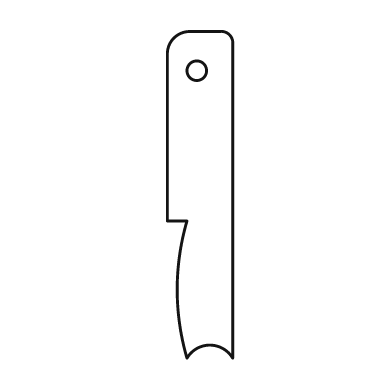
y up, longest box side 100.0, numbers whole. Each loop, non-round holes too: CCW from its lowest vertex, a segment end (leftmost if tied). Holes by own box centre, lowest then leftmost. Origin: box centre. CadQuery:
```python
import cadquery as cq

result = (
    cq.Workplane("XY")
    .moveTo(-4.0, -50.0)
    .threePointArc((3.0, -46.0), (10.0, -50.0))
    .lineTo(10.0, 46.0)
    .threePointArc((9.0, 49.0), (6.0, 50.0))
    .lineTo(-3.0, 50.0)
    .threePointArc((-8.0, 48.0), (-10.0, 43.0))
    .lineTo(-10.0, -8.0)
    .lineTo(-4.0, -8.0)
    .threePointArc((-7.0, -29.0), (-4.0, -50.0))
    .close()
    .moveTo(-1.0, 38.0)
    .circle(3.0)
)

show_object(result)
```